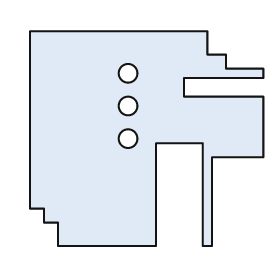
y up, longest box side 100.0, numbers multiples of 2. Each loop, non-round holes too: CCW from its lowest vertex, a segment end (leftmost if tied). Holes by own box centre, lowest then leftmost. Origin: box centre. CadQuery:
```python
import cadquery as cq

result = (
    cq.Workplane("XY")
    .moveTo(-38.0, -46.0)
    .lineTo(4.0, -46.0)
    .lineTo(4.0, -2.0)
    .lineTo(24.0, -2.0)
    .lineTo(24.0, -46.0)
    .lineTo(28.0, -46.0)
    .lineTo(28.0, -8.0)
    .lineTo(50.0, -8.0)
    .lineTo(50.0, 18.0)
    .lineTo(16.0, 18.0)
    .lineTo(16.0, 26.0)
    .lineTo(50.0, 26.0)
    .lineTo(50.0, 30.0)
    .lineTo(34.0, 30.0)
    .lineTo(34.0, 36.0)
    .lineTo(26.0, 36.0)
    .lineTo(26.0, 46.0)
    .lineTo(-50.0, 46.0)
    .lineTo(-50.0, -30.0)
    .lineTo(-44.0, -30.0)
    .lineTo(-44.0, -36.0)
    .lineTo(-38.0, -36.0)
    .close()
    .moveTo(-8.0, 0.0)
    .circle(4.0)
    .moveTo(-8.0, 14.0)
    .circle(4.0)
    .moveTo(-8.0, 28.0)
    .circle(4.0)
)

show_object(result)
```